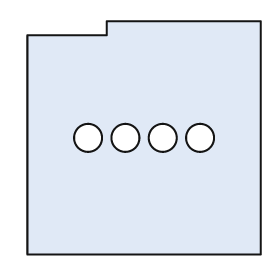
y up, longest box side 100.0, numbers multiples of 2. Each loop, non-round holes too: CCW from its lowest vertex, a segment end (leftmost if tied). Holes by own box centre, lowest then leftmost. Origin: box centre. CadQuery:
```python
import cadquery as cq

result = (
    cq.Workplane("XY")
    .moveTo(-50.0, -50.0)
    .lineTo(50.0, -50.0)
    .lineTo(50.0, 50.0)
    .lineTo(-16.0, 50.0)
    .lineTo(-16.0, 44.0)
    .lineTo(-50.0, 44.0)
    .close()
    .moveTo(-24.0, 0.0)
    .circle(6.0)
    .moveTo(-8.0, 0.0)
    .circle(6.0)
    .moveTo(8.0, 0.0)
    .circle(6.0)
    .moveTo(24.0, 0.0)
    .circle(6.0)
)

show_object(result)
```